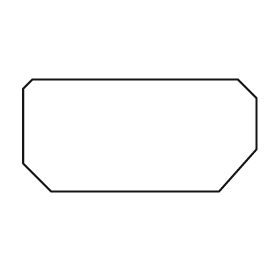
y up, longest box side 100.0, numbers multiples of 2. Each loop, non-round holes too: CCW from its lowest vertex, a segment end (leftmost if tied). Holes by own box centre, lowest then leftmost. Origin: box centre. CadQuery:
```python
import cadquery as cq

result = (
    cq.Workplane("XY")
    .moveTo(-38.0, -24.0)
    .lineTo(34.0, -24.0)
    .lineTo(50.0, -6.0)
    .lineTo(50.0, 16.0)
    .lineTo(42.0, 24.0)
    .lineTo(-46.0, 24.0)
    .lineTo(-50.0, 20.0)
    .lineTo(-50.0, -12.0)
    .close()
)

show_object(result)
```